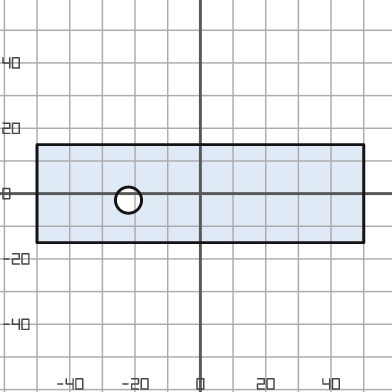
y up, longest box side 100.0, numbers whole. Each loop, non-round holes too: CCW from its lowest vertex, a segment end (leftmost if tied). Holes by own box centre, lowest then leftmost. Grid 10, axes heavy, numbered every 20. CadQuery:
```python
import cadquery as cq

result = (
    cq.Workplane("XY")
    .moveTo(-50.0, -15.0)
    .lineTo(50.0, -15.0)
    .lineTo(50.0, 15.0)
    .lineTo(-50.0, 15.0)
    .close()
    .moveTo(-22.0, -2.0)
    .circle(4.0)
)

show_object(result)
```